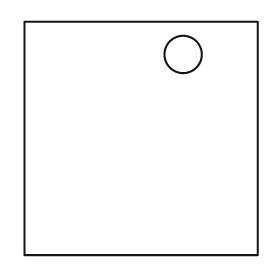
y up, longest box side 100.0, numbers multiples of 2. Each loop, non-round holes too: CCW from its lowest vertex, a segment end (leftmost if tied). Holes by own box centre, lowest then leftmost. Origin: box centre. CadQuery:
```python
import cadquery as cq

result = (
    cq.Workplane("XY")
    .moveTo(-50.0, -50.0)
    .lineTo(50.0, -50.0)
    .lineTo(50.0, 50.0)
    .lineTo(-50.0, 50.0)
    .close()
    .moveTo(18.0, 36.0)
    .circle(8.0)
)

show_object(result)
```